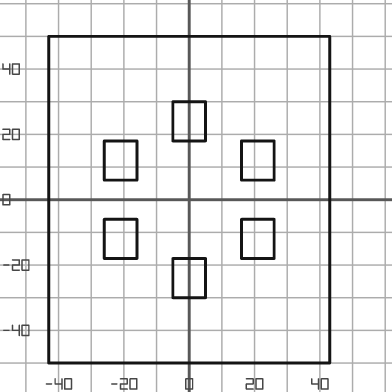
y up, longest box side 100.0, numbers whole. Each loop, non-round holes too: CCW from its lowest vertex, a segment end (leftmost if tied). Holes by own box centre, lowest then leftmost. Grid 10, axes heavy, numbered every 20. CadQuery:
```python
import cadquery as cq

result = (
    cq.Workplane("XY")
    .moveTo(-43.0, -50.0)
    .lineTo(43.0, -50.0)
    .lineTo(43.0, 50.0)
    .lineTo(-43.0, 50.0)
    .close()
    .moveTo(-5.0, -30.0)
    .lineTo(5.0, -30.0)
    .lineTo(5.0, -18.0)
    .lineTo(-5.0, -18.0)
    .close()
    .moveTo(-26.0, -18.0)
    .lineTo(-16.0, -18.0)
    .lineTo(-16.0, -6.0)
    .lineTo(-26.0, -6.0)
    .close()
    .moveTo(16.0, -18.0)
    .lineTo(26.0, -18.0)
    .lineTo(26.0, -6.0)
    .lineTo(16.0, -6.0)
    .close()
    .moveTo(-26.0, 6.0)
    .lineTo(-16.0, 6.0)
    .lineTo(-16.0, 18.0)
    .lineTo(-26.0, 18.0)
    .close()
    .moveTo(16.0, 6.0)
    .lineTo(26.0, 6.0)
    .lineTo(26.0, 18.0)
    .lineTo(16.0, 18.0)
    .close()
    .moveTo(-5.0, 18.0)
    .lineTo(5.0, 18.0)
    .lineTo(5.0, 30.0)
    .lineTo(-5.0, 30.0)
    .close()
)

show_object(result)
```